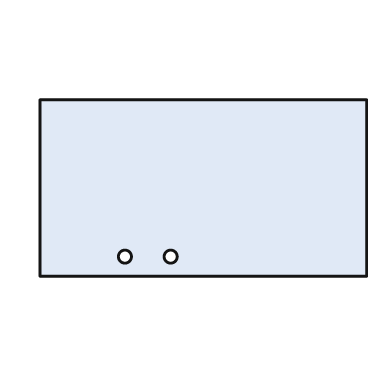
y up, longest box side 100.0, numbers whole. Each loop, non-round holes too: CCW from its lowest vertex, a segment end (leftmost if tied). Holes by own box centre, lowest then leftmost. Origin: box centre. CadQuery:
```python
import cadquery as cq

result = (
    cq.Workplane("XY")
    .moveTo(-50.0, -27.0)
    .lineTo(50.0, -27.0)
    .lineTo(50.0, 27.0)
    .lineTo(-50.0, 27.0)
    .close()
    .moveTo(-24.0, -21.0)
    .circle(2.0)
    .moveTo(-10.0, -21.0)
    .circle(2.0)
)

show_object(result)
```